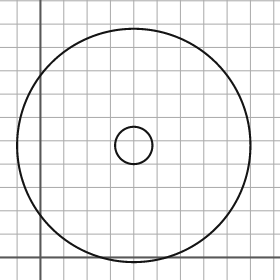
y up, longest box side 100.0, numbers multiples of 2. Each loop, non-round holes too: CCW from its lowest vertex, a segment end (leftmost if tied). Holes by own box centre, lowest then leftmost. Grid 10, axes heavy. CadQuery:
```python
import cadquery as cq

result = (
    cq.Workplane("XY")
    .moveTo(40.0, 48.0)
    .circle(50.0)
    .moveTo(40.0, 48.0)
    .circle(8.0)
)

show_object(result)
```